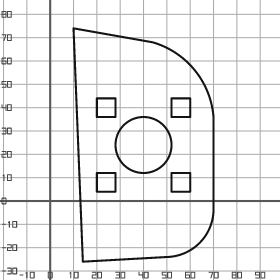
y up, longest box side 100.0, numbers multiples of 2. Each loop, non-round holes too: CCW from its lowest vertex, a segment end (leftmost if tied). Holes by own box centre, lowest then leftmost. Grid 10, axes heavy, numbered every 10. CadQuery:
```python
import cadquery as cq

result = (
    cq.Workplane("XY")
    .moveTo(14.0, -26.0)
    .lineTo(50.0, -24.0)
    .threePointArc((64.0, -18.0), (70.0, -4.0))
    .lineTo(70.0, 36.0)
    .threePointArc((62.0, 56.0), (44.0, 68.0))
    .lineTo(10.0, 74.0)
    .close()
    .moveTo(20.0, 4.0)
    .lineTo(28.0, 4.0)
    .lineTo(28.0, 12.0)
    .lineTo(20.0, 12.0)
    .close()
    .moveTo(52.0, 4.0)
    .lineTo(60.0, 4.0)
    .lineTo(60.0, 12.0)
    .lineTo(52.0, 12.0)
    .close()
    .moveTo(40.0, 24.0)
    .circle(12.0)
    .moveTo(20.0, 36.0)
    .lineTo(28.0, 36.0)
    .lineTo(28.0, 44.0)
    .lineTo(20.0, 44.0)
    .close()
    .moveTo(52.0, 36.0)
    .lineTo(60.0, 36.0)
    .lineTo(60.0, 44.0)
    .lineTo(52.0, 44.0)
    .close()
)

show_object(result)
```